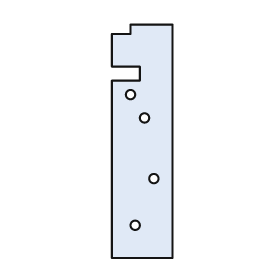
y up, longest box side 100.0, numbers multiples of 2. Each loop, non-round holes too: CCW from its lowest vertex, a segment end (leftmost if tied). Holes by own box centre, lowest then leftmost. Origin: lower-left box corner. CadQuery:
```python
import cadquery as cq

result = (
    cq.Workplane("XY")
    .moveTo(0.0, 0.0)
    .lineTo(26.0, 0.0)
    .lineTo(26.0, 100.0)
    .lineTo(8.0, 100.0)
    .lineTo(8.0, 96.0)
    .lineTo(0.0, 96.0)
    .lineTo(0.0, 82.0)
    .lineTo(12.0, 82.0)
    .lineTo(12.0, 76.0)
    .lineTo(0.0, 76.0)
    .close()
    .moveTo(10.0, 14.0)
    .circle(2.0)
    .moveTo(18.0, 34.0)
    .circle(2.0)
    .moveTo(14.0, 60.0)
    .circle(2.0)
    .moveTo(8.0, 70.0)
    .circle(2.0)
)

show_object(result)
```